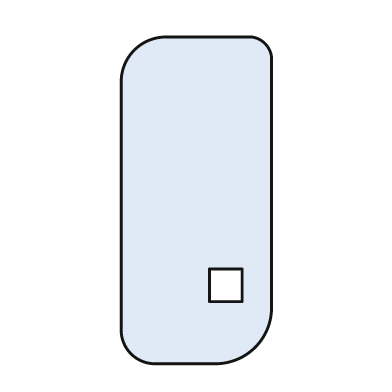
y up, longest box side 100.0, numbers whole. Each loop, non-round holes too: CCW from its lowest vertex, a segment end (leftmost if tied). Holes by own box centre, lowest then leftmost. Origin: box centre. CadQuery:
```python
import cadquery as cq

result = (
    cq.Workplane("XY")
    .moveTo(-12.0, -50.0)
    .lineTo(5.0, -50.0)
    .threePointArc((18.0, -45.0), (23.0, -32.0))
    .lineTo(23.0, 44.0)
    .threePointArc((21.0, 48.0), (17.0, 50.0))
    .lineTo(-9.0, 50.0)
    .threePointArc((-19.0, 46.0), (-23.0, 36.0))
    .lineTo(-23.0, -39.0)
    .threePointArc((-20.0, -47.0), (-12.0, -50.0))
    .close()
    .moveTo(4.0, -31.0)
    .lineTo(14.0, -31.0)
    .lineTo(14.0, -21.0)
    .lineTo(4.0, -21.0)
    .close()
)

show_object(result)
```